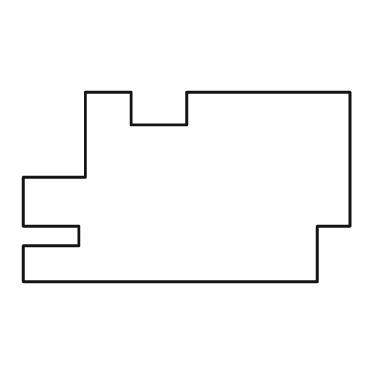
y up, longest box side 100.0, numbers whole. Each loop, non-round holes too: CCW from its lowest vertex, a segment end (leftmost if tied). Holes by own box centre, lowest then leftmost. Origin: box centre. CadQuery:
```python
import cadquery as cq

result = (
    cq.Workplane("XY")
    .moveTo(-50.0, -29.0)
    .lineTo(40.0, -29.0)
    .lineTo(40.0, -12.0)
    .lineTo(50.0, -12.0)
    .lineTo(50.0, 29.0)
    .lineTo(0.0, 29.0)
    .lineTo(0.0, 19.0)
    .lineTo(-17.0, 19.0)
    .lineTo(-17.0, 29.0)
    .lineTo(-31.0, 29.0)
    .lineTo(-31.0, 3.0)
    .lineTo(-50.0, 3.0)
    .lineTo(-50.0, -12.0)
    .lineTo(-33.0, -12.0)
    .lineTo(-33.0, -18.0)
    .lineTo(-50.0, -18.0)
    .close()
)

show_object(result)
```